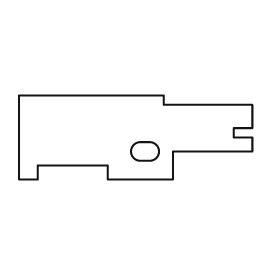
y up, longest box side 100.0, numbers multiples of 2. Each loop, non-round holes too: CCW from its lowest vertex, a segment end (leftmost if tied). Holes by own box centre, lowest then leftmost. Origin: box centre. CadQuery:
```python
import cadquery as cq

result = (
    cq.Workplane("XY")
    .moveTo(-50.0, -18.0)
    .lineTo(-42.0, -18.0)
    .lineTo(-42.0, -12.0)
    .lineTo(-12.0, -12.0)
    .lineTo(-12.0, -18.0)
    .lineTo(16.0, -18.0)
    .lineTo(16.0, -6.0)
    .lineTo(50.0, -6.0)
    .lineTo(50.0, 0.0)
    .lineTo(42.0, 0.0)
    .lineTo(42.0, 4.0)
    .lineTo(50.0, 4.0)
    .lineTo(50.0, 14.0)
    .lineTo(12.0, 14.0)
    .lineTo(12.0, 18.0)
    .lineTo(-50.0, 18.0)
    .close()
    .moveTo(2.0, -10.0)
    .lineTo(6.0, -10.0)
    .threePointArc((10.0, -6.0), (6.0, -2.0))
    .lineTo(2.0, -2.0)
    .threePointArc((-2.0, -6.0), (2.0, -10.0))
    .close()
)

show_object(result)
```